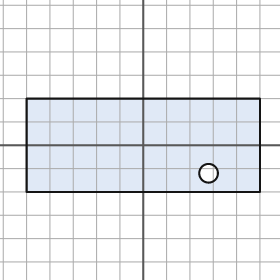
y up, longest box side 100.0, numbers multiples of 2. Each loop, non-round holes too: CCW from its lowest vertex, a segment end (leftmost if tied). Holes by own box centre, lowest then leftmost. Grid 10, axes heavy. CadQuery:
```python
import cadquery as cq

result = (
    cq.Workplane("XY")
    .moveTo(-50.0, -20.0)
    .lineTo(50.0, -20.0)
    .lineTo(50.0, 20.0)
    .lineTo(-50.0, 20.0)
    .close()
    .moveTo(28.0, -12.0)
    .circle(4.0)
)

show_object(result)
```